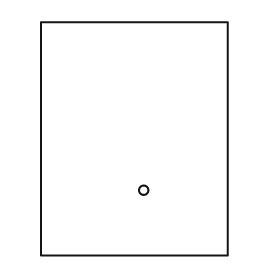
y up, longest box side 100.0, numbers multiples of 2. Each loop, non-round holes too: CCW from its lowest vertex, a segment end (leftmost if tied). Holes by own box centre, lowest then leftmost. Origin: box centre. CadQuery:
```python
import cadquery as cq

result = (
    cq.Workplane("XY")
    .moveTo(-40.0, -50.0)
    .lineTo(40.0, -50.0)
    .lineTo(40.0, 50.0)
    .lineTo(-40.0, 50.0)
    .close()
    .moveTo(4.0, -22.0)
    .circle(2.0)
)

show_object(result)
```